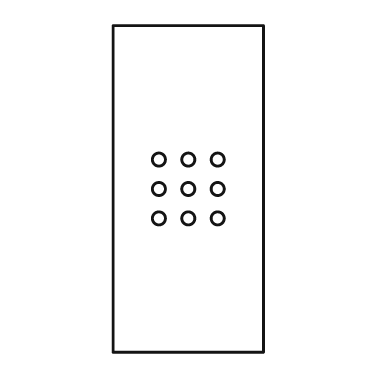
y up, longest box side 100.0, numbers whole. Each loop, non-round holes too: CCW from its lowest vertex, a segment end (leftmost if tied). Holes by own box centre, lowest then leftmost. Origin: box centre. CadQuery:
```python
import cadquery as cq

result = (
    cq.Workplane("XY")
    .moveTo(-23.0, -50.0)
    .lineTo(23.0, -50.0)
    .lineTo(23.0, 50.0)
    .lineTo(-23.0, 50.0)
    .close()
    .moveTo(-9.0, -9.0)
    .circle(2.0)
    .moveTo(0.0, -9.0)
    .circle(2.0)
    .moveTo(9.0, -9.0)
    .circle(2.0)
    .moveTo(-9.0, 0.0)
    .circle(2.0)
    .moveTo(0.0, 0.0)
    .circle(2.0)
    .moveTo(9.0, 0.0)
    .circle(2.0)
    .moveTo(-9.0, 9.0)
    .circle(2.0)
    .moveTo(0.0, 9.0)
    .circle(2.0)
    .moveTo(9.0, 9.0)
    .circle(2.0)
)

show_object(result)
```